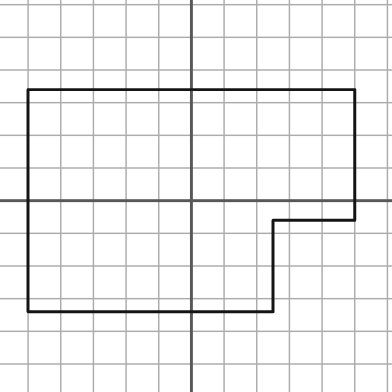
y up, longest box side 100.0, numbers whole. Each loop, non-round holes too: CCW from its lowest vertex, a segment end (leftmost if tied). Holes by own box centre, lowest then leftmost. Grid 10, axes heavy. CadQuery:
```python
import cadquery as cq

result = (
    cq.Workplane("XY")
    .moveTo(-50.0, -34.0)
    .lineTo(25.0, -34.0)
    .lineTo(25.0, -6.0)
    .lineTo(50.0, -6.0)
    .lineTo(50.0, 34.0)
    .lineTo(-50.0, 34.0)
    .close()
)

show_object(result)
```